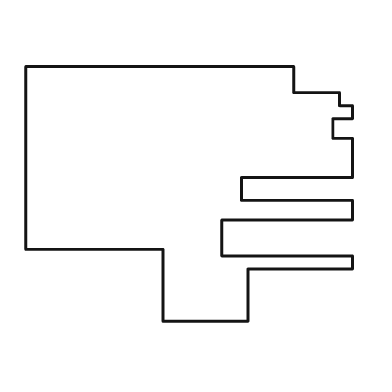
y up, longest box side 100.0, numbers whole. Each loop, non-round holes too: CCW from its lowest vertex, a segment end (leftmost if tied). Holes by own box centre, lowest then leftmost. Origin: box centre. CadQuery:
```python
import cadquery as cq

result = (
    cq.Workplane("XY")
    .moveTo(-8.0, -39.0)
    .lineTo(18.0, -39.0)
    .lineTo(18.0, -23.0)
    .lineTo(50.0, -23.0)
    .lineTo(50.0, -19.0)
    .lineTo(10.0, -19.0)
    .lineTo(10.0, -8.0)
    .lineTo(50.0, -8.0)
    .lineTo(50.0, -2.0)
    .lineTo(16.0, -2.0)
    .lineTo(16.0, 5.0)
    .lineTo(50.0, 5.0)
    .lineTo(50.0, 17.0)
    .lineTo(44.0, 17.0)
    .lineTo(44.0, 23.0)
    .lineTo(50.0, 23.0)
    .lineTo(50.0, 27.0)
    .lineTo(46.0, 27.0)
    .lineTo(46.0, 31.0)
    .lineTo(32.0, 31.0)
    .lineTo(32.0, 39.0)
    .lineTo(-50.0, 39.0)
    .lineTo(-50.0, -17.0)
    .lineTo(-8.0, -17.0)
    .close()
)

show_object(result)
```